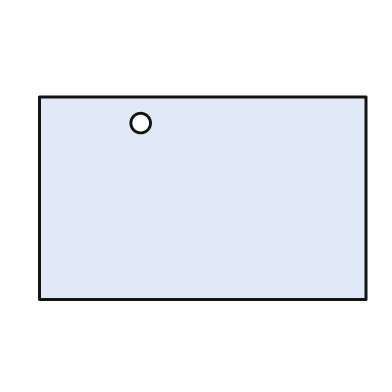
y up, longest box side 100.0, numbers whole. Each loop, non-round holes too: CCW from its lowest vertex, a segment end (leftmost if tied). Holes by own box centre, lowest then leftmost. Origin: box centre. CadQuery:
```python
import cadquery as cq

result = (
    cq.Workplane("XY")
    .moveTo(-50.0, -31.0)
    .lineTo(50.0, -31.0)
    .lineTo(50.0, 31.0)
    .lineTo(-50.0, 31.0)
    .close()
    .moveTo(-19.0, 23.0)
    .circle(3.0)
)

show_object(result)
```